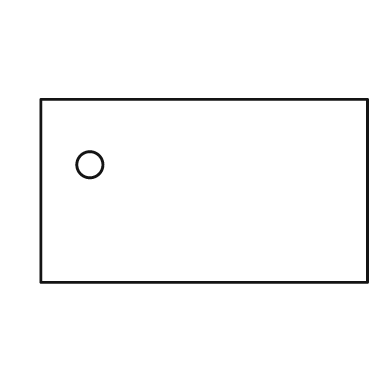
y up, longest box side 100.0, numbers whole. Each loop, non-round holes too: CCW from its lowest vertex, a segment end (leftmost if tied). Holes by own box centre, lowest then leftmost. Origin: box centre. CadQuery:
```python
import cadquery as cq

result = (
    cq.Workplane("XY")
    .moveTo(-50.0, -28.0)
    .lineTo(50.0, -28.0)
    .lineTo(50.0, 28.0)
    .lineTo(-50.0, 28.0)
    .close()
    .moveTo(-35.0, 8.0)
    .circle(4.0)
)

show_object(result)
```